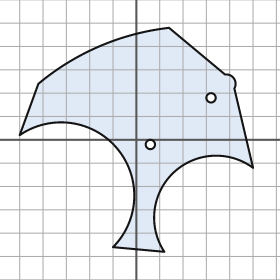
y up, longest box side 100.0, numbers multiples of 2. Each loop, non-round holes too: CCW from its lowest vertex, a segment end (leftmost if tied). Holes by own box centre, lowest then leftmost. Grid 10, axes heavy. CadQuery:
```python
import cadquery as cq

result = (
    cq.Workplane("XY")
    .moveTo(12.0, -48.0)
    .threePointArc((16.0, -14.0), (50.0, -12.0))
    .lineTo(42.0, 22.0)
    .threePointArc((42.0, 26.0), (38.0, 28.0))
    .lineTo(14.0, 48.0)
    .threePointArc((-16.0, 40.0), (-42.0, 24.0))
    .lineTo(-50.0, 2.0)
    .threePointArc((-8.0, -4.0), (-10.0, -46.0))
    .close()
    .moveTo(6.0, -2.0)
    .circle(2.0)
    .moveTo(32.0, 18.0)
    .circle(2.0)
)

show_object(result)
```